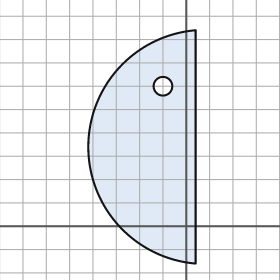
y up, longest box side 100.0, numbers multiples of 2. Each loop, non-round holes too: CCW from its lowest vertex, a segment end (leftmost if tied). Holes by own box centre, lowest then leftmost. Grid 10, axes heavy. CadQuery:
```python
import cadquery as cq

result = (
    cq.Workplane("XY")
    .moveTo(4.0, -16.0)
    .lineTo(4.0, 84.0)
    .threePointArc((-42.0, 34.0), (4.0, -16.0))
    .close()
    .moveTo(-10.0, 60.0)
    .circle(4.0)
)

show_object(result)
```